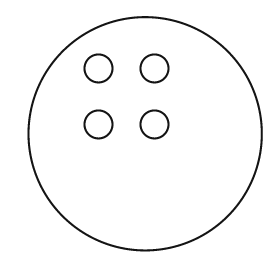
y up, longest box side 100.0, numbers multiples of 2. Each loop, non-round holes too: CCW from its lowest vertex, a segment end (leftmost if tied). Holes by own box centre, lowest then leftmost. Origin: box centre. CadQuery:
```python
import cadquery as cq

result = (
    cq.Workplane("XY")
    .moveTo(0.0, 0.0)
    .circle(50.0)
    .moveTo(-20.0, 4.0)
    .circle(6.0)
    .moveTo(4.0, 4.0)
    .circle(6.0)
    .moveTo(-20.0, 28.0)
    .circle(6.0)
    .moveTo(4.0, 28.0)
    .circle(6.0)
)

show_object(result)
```